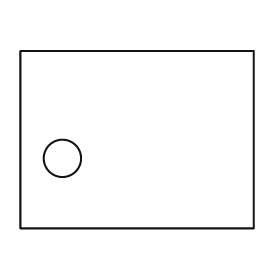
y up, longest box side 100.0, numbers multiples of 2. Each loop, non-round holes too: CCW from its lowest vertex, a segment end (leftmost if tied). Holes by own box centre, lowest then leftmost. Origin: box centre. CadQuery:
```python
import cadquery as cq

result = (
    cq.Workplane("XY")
    .moveTo(-50.0, -38.0)
    .lineTo(50.0, -38.0)
    .lineTo(50.0, 38.0)
    .lineTo(-50.0, 38.0)
    .close()
    .moveTo(-32.0, -8.0)
    .circle(8.0)
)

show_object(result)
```